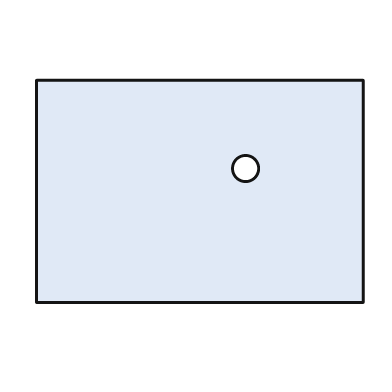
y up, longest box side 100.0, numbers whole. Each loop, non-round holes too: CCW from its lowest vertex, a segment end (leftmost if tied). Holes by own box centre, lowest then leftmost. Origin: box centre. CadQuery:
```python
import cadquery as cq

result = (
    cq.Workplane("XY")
    .moveTo(-50.0, -34.0)
    .lineTo(50.0, -34.0)
    .lineTo(50.0, 34.0)
    .lineTo(-50.0, 34.0)
    .close()
    .moveTo(14.0, 7.0)
    .circle(4.0)
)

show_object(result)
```